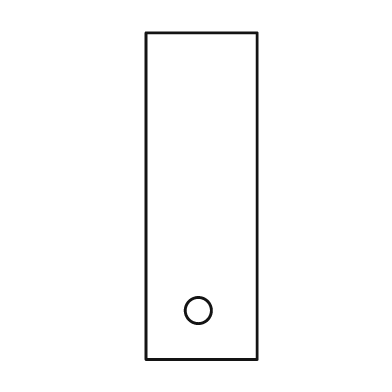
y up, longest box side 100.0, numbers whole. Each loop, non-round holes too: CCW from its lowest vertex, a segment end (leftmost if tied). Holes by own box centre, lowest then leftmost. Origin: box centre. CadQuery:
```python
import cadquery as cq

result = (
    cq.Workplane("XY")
    .moveTo(-17.0, -50.0)
    .lineTo(17.0, -50.0)
    .lineTo(17.0, 50.0)
    .lineTo(-17.0, 50.0)
    .close()
    .moveTo(-1.0, -35.0)
    .circle(4.0)
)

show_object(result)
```